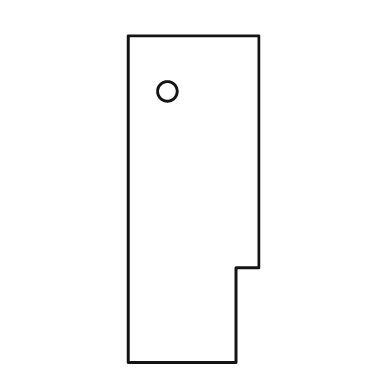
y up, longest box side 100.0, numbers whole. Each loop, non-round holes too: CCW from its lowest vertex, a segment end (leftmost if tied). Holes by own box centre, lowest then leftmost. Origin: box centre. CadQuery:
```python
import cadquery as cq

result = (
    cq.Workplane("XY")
    .moveTo(-20.0, -50.0)
    .lineTo(13.0, -50.0)
    .lineTo(13.0, -21.0)
    .lineTo(20.0, -21.0)
    .lineTo(20.0, 50.0)
    .lineTo(-20.0, 50.0)
    .close()
    .moveTo(-8.0, 33.0)
    .circle(3.0)
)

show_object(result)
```